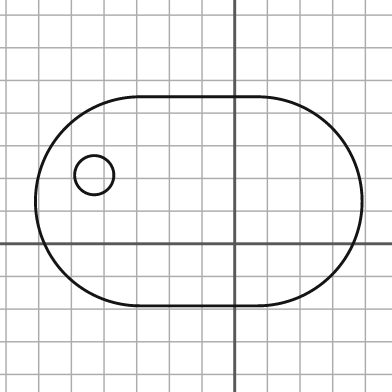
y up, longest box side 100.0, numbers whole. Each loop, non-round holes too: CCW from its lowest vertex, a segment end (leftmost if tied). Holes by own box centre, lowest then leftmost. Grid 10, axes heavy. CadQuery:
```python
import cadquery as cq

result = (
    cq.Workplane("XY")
    .moveTo(-29.0, -19.0)
    .lineTo(7.0, -19.0)
    .threePointArc((39.0, 13.0), (7.0, 45.0))
    .lineTo(-29.0, 45.0)
    .threePointArc((-61.0, 13.0), (-29.0, -19.0))
    .close()
    .moveTo(-43.0, 21.0)
    .circle(6.0)
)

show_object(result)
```